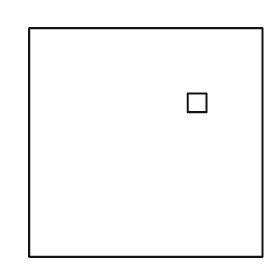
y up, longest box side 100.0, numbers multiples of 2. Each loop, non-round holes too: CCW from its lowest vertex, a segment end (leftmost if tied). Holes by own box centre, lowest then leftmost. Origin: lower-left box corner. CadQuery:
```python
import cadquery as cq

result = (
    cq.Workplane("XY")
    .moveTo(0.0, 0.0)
    .lineTo(100.0, 0.0)
    .lineTo(100.0, 98.0)
    .lineTo(0.0, 98.0)
    .close()
    .moveTo(68.0, 62.0)
    .lineTo(76.0, 62.0)
    .lineTo(76.0, 70.0)
    .lineTo(68.0, 70.0)
    .close()
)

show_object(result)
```